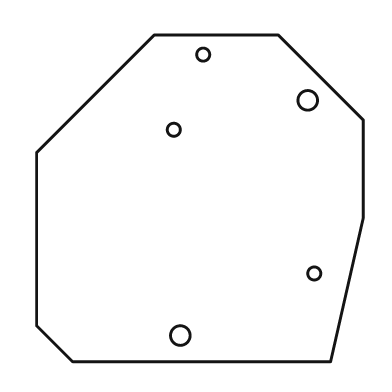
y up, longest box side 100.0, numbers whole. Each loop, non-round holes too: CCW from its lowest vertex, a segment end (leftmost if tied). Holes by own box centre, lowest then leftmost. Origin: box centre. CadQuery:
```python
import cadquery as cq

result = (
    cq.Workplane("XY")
    .moveTo(-39.0, -50.0)
    .lineTo(40.0, -50.0)
    .lineTo(50.0, -6.0)
    .lineTo(50.0, 24.0)
    .lineTo(24.0, 50.0)
    .lineTo(-14.0, 50.0)
    .lineTo(-50.0, 14.0)
    .lineTo(-50.0, -39.0)
    .close()
    .moveTo(-6.0, -42.0)
    .circle(3.0)
    .moveTo(35.0, -23.0)
    .circle(2.0)
    .moveTo(-8.0, 21.0)
    .circle(2.0)
    .moveTo(33.0, 30.0)
    .circle(3.0)
    .moveTo(1.0, 44.0)
    .circle(2.0)
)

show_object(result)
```